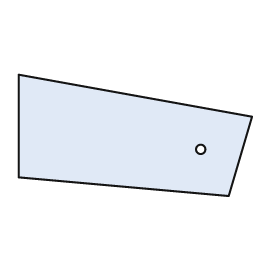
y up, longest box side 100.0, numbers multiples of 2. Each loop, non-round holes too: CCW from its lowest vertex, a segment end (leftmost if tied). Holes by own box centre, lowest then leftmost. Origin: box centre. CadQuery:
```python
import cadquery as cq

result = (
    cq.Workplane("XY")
    .moveTo(40.0, -26.0)
    .lineTo(50.0, 8.0)
    .lineTo(-50.0, 26.0)
    .lineTo(-50.0, -18.0)
    .close()
    .moveTo(28.0, -6.0)
    .circle(2.0)
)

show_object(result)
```